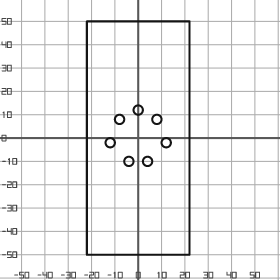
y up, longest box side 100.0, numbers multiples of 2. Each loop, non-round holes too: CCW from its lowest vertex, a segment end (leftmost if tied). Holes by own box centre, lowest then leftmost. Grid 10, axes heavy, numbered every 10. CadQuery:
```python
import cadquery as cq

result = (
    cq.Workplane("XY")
    .moveTo(-22.0, -50.0)
    .lineTo(22.0, -50.0)
    .lineTo(22.0, 50.0)
    .lineTo(-22.0, 50.0)
    .close()
    .moveTo(-4.0, -10.0)
    .circle(2.0)
    .moveTo(4.0, -10.0)
    .circle(2.0)
    .moveTo(-12.0, -2.0)
    .circle(2.0)
    .moveTo(12.0, -2.0)
    .circle(2.0)
    .moveTo(-8.0, 8.0)
    .circle(2.0)
    .moveTo(8.0, 8.0)
    .circle(2.0)
    .moveTo(0.0, 12.0)
    .circle(2.0)
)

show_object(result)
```